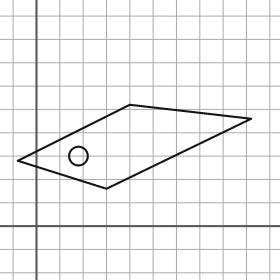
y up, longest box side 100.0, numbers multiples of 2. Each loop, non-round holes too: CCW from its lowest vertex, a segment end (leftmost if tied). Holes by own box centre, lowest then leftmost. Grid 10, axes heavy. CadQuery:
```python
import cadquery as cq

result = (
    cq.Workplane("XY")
    .moveTo(30.0, 16.0)
    .lineTo(92.0, 46.0)
    .lineTo(40.0, 52.0)
    .lineTo(-8.0, 28.0)
    .close()
    .moveTo(18.0, 30.0)
    .circle(4.0)
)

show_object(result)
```